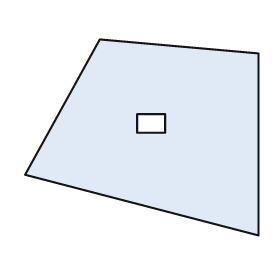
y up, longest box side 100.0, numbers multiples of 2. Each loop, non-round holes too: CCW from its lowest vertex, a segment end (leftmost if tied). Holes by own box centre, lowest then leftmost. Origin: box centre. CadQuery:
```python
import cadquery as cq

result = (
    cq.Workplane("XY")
    .moveTo(50.0, -42.0)
    .lineTo(50.0, 36.0)
    .lineTo(-18.0, 42.0)
    .lineTo(-50.0, -16.0)
    .close()
    .moveTo(-2.0, 2.0)
    .lineTo(10.0, 2.0)
    .lineTo(10.0, 10.0)
    .lineTo(-2.0, 10.0)
    .close()
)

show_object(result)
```